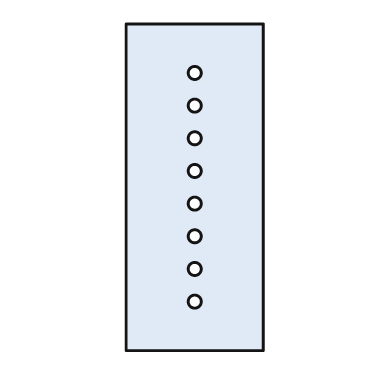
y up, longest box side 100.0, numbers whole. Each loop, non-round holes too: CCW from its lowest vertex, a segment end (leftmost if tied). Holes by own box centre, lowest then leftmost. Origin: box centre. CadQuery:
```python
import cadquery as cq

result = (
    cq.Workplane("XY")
    .moveTo(-21.0, -50.0)
    .lineTo(21.0, -50.0)
    .lineTo(21.0, 50.0)
    .lineTo(-21.0, 50.0)
    .close()
    .moveTo(0.0, -35.0)
    .circle(2.0)
    .moveTo(0.0, -25.0)
    .circle(2.0)
    .moveTo(0.0, -15.0)
    .circle(2.0)
    .moveTo(0.0, -5.0)
    .circle(2.0)
    .moveTo(0.0, 5.0)
    .circle(2.0)
    .moveTo(0.0, 15.0)
    .circle(2.0)
    .moveTo(0.0, 25.0)
    .circle(2.0)
    .moveTo(0.0, 35.0)
    .circle(2.0)
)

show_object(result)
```